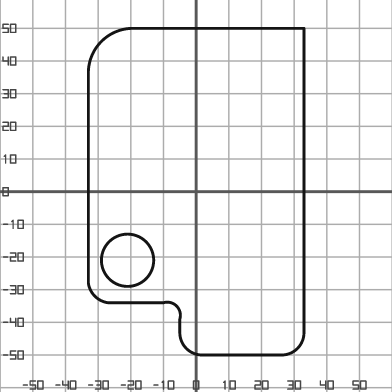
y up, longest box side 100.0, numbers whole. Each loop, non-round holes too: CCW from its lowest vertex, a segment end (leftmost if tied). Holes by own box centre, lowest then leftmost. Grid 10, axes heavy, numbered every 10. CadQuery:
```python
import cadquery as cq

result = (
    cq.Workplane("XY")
    .moveTo(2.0, -50.0)
    .lineTo(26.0, -50.0)
    .threePointArc((31.0, -48.0), (33.0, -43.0))
    .lineTo(33.0, 50.0)
    .lineTo(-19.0, 50.0)
    .threePointArc((-29.0, 46.0), (-33.0, 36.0))
    .lineTo(-33.0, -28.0)
    .threePointArc((-31.0, -32.0), (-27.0, -34.0))
    .lineTo(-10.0, -34.0)
    .threePointArc((-6.0, -35.0), (-5.0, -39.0))
    .lineTo(-5.0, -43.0)
    .threePointArc((-3.0, -48.0), (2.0, -50.0))
    .close()
    .moveTo(-21.0, -21.0)
    .circle(8.0)
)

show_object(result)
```